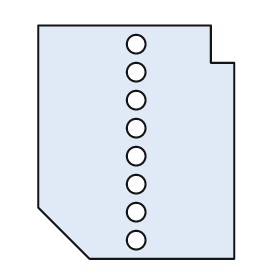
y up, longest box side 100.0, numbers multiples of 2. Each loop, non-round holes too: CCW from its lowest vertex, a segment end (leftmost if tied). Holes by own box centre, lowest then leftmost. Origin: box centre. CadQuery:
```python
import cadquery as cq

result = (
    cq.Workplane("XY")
    .moveTo(-20.0, -50.0)
    .lineTo(42.0, -50.0)
    .lineTo(42.0, 34.0)
    .lineTo(32.0, 34.0)
    .lineTo(32.0, 50.0)
    .lineTo(-42.0, 50.0)
    .lineTo(-42.0, -28.0)
    .close()
    .moveTo(0.0, -42.0)
    .circle(4.0)
    .moveTo(0.0, -30.0)
    .circle(4.0)
    .moveTo(0.0, -18.0)
    .circle(4.0)
    .moveTo(0.0, -6.0)
    .circle(4.0)
    .moveTo(0.0, 6.0)
    .circle(4.0)
    .moveTo(0.0, 18.0)
    .circle(4.0)
    .moveTo(0.0, 30.0)
    .circle(4.0)
    .moveTo(0.0, 42.0)
    .circle(4.0)
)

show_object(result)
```